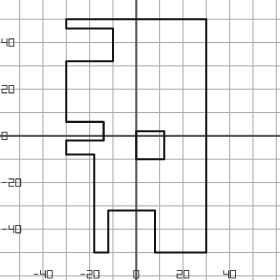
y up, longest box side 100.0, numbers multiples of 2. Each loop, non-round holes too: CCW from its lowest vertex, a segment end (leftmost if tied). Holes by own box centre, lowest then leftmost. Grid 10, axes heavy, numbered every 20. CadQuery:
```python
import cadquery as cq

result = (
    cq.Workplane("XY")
    .moveTo(-18.0, -50.0)
    .lineTo(-12.0, -50.0)
    .lineTo(-12.0, -32.0)
    .lineTo(8.0, -32.0)
    .lineTo(8.0, -50.0)
    .lineTo(30.0, -50.0)
    .lineTo(30.0, 50.0)
    .lineTo(-30.0, 50.0)
    .lineTo(-30.0, 46.0)
    .lineTo(-10.0, 46.0)
    .lineTo(-10.0, 32.0)
    .lineTo(-30.0, 32.0)
    .lineTo(-30.0, 6.0)
    .lineTo(-14.0, 6.0)
    .lineTo(-14.0, -2.0)
    .lineTo(-30.0, -2.0)
    .lineTo(-30.0, -8.0)
    .lineTo(-18.0, -8.0)
    .close()
    .moveTo(0.0, -10.0)
    .lineTo(12.0, -10.0)
    .lineTo(12.0, 2.0)
    .lineTo(0.0, 2.0)
    .close()
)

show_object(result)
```